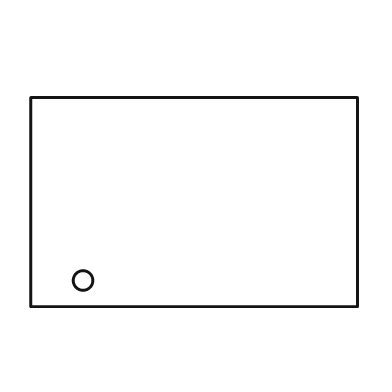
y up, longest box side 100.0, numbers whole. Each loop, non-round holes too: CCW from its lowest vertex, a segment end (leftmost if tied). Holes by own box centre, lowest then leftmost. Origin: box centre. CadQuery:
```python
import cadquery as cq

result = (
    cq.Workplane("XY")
    .moveTo(-50.0, -32.0)
    .lineTo(50.0, -32.0)
    .lineTo(50.0, 32.0)
    .lineTo(-50.0, 32.0)
    .close()
    .moveTo(-34.0, -24.0)
    .circle(3.0)
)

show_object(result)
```